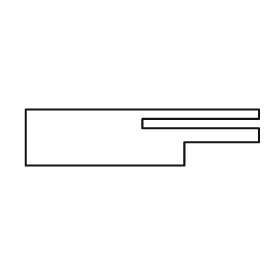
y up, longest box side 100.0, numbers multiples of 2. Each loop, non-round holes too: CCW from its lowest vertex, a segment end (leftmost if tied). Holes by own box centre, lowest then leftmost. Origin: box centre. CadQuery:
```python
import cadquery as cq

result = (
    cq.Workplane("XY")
    .moveTo(-50.0, -12.0)
    .lineTo(18.0, -12.0)
    .lineTo(18.0, -2.0)
    .lineTo(50.0, -2.0)
    .lineTo(50.0, 4.0)
    .lineTo(0.0, 4.0)
    .lineTo(0.0, 8.0)
    .lineTo(50.0, 8.0)
    .lineTo(50.0, 12.0)
    .lineTo(-50.0, 12.0)
    .close()
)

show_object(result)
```